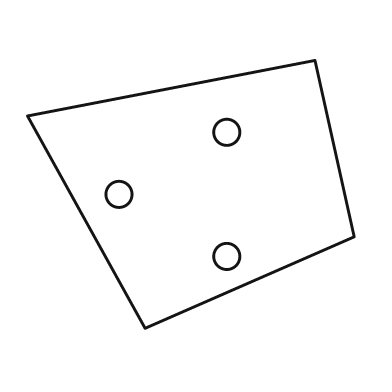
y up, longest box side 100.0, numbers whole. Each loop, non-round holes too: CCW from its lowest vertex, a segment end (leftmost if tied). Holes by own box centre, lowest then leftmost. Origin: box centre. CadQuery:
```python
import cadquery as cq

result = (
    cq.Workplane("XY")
    .moveTo(-14.0, -41.0)
    .lineTo(50.0, -13.0)
    .lineTo(38.0, 41.0)
    .lineTo(-50.0, 24.0)
    .close()
    .moveTo(11.0, -19.0)
    .circle(4.0)
    .moveTo(-22.0, 0.0)
    .circle(4.0)
    .moveTo(11.0, 19.0)
    .circle(4.0)
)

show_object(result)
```